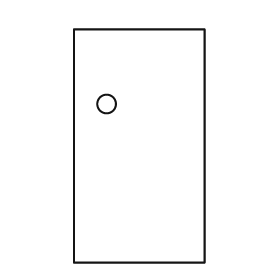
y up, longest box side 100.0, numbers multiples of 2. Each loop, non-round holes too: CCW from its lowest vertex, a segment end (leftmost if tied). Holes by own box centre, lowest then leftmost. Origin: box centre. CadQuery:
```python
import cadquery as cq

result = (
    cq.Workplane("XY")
    .moveTo(-28.0, -50.0)
    .lineTo(28.0, -50.0)
    .lineTo(28.0, 50.0)
    .lineTo(-28.0, 50.0)
    .close()
    .moveTo(-14.0, 18.0)
    .circle(4.0)
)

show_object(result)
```